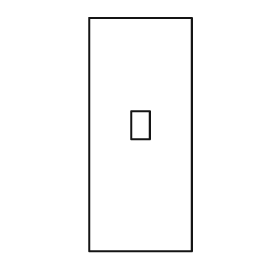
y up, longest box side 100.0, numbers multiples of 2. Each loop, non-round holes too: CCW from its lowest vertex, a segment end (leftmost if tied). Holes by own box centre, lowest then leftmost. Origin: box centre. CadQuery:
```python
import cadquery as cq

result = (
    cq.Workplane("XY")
    .moveTo(-22.0, -50.0)
    .lineTo(22.0, -50.0)
    .lineTo(22.0, 50.0)
    .lineTo(-22.0, 50.0)
    .close()
    .moveTo(-4.0, -2.0)
    .lineTo(4.0, -2.0)
    .lineTo(4.0, 10.0)
    .lineTo(-4.0, 10.0)
    .close()
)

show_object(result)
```